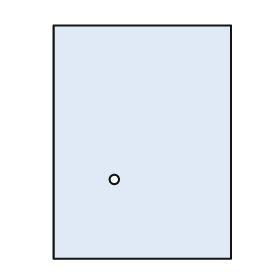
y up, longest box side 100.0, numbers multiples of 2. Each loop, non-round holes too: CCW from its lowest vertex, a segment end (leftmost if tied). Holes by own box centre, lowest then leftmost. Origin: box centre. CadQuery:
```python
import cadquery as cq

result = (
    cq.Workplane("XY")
    .moveTo(-38.0, -50.0)
    .lineTo(38.0, -50.0)
    .lineTo(38.0, 50.0)
    .lineTo(-38.0, 50.0)
    .close()
    .moveTo(-12.0, -16.0)
    .circle(2.0)
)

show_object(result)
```